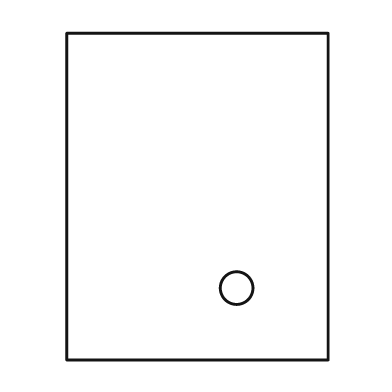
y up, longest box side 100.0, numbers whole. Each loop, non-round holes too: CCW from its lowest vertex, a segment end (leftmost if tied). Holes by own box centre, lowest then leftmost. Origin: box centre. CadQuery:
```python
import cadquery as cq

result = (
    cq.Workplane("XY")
    .moveTo(-40.0, -50.0)
    .lineTo(40.0, -50.0)
    .lineTo(40.0, 50.0)
    .lineTo(-40.0, 50.0)
    .close()
    .moveTo(12.0, -28.0)
    .circle(5.0)
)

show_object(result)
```